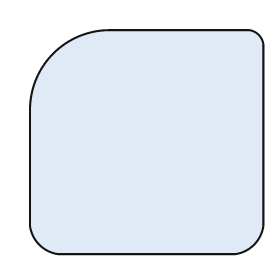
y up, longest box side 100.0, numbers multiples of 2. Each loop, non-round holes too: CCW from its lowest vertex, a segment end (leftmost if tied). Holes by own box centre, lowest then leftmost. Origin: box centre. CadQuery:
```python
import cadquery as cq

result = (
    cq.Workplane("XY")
    .moveTo(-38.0, -48.0)
    .lineTo(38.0, -48.0)
    .threePointArc((46.0, -44.0), (50.0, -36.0))
    .lineTo(50.0, 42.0)
    .threePointArc((48.0, 46.0), (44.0, 48.0))
    .lineTo(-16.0, 48.0)
    .threePointArc((-40.0, 38.0), (-50.0, 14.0))
    .lineTo(-50.0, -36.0)
    .threePointArc((-46.0, -44.0), (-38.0, -48.0))
    .close()
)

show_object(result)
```